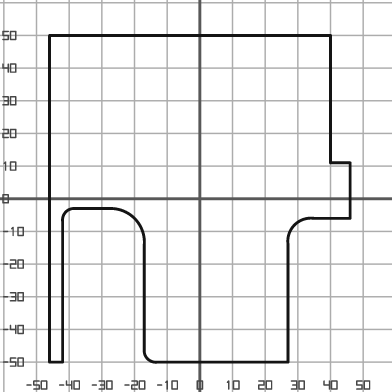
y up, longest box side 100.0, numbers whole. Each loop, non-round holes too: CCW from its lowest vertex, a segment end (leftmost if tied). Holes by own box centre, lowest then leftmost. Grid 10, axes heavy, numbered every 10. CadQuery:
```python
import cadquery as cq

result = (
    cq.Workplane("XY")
    .moveTo(-46.0, -50.0)
    .lineTo(-42.0, -50.0)
    .lineTo(-42.0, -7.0)
    .threePointArc((-41.0, -4.0), (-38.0, -3.0))
    .lineTo(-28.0, -3.0)
    .threePointArc((-20.0, -6.0), (-17.0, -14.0))
    .lineTo(-17.0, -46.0)
    .threePointArc((-16.0, -49.0), (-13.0, -50.0))
    .lineTo(27.0, -50.0)
    .lineTo(27.0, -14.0)
    .threePointArc((29.0, -8.0), (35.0, -6.0))
    .lineTo(46.0, -6.0)
    .lineTo(46.0, 11.0)
    .lineTo(40.0, 11.0)
    .lineTo(40.0, 50.0)
    .lineTo(-46.0, 50.0)
    .close()
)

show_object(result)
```